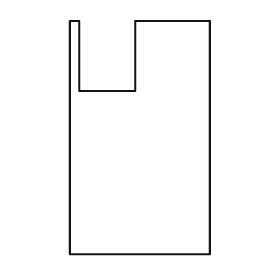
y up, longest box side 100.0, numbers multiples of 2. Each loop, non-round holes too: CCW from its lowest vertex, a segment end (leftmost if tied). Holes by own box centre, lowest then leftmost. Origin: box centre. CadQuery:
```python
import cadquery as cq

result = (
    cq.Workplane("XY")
    .moveTo(-30.0, -50.0)
    .lineTo(30.0, -50.0)
    .lineTo(30.0, 50.0)
    .lineTo(-2.0, 50.0)
    .lineTo(-2.0, 20.0)
    .lineTo(-26.0, 20.0)
    .lineTo(-26.0, 50.0)
    .lineTo(-30.0, 50.0)
    .close()
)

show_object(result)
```